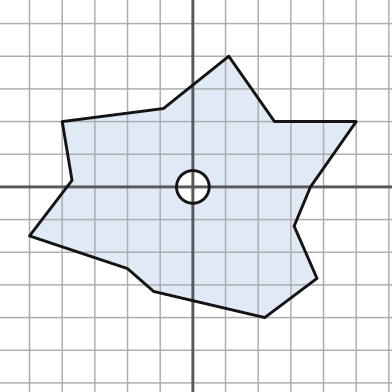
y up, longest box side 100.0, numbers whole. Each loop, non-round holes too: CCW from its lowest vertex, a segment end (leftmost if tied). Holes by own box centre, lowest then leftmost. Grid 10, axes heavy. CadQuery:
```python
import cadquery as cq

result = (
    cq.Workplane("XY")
    .moveTo(22.0, -40.0)
    .lineTo(38.0, -28.0)
    .lineTo(31.0, -12.0)
    .lineTo(36.0, 0.0)
    .lineTo(50.0, 20.0)
    .lineTo(25.0, 20.0)
    .lineTo(11.0, 40.0)
    .lineTo(-9.0, 24.0)
    .lineTo(-40.0, 20.0)
    .lineTo(-37.0, 2.0)
    .lineTo(-50.0, -15.0)
    .lineTo(-20.0, -25.0)
    .lineTo(-12.0, -32.0)
    .close()
    .moveTo(0.0, 0.0)
    .circle(5.0)
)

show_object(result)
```